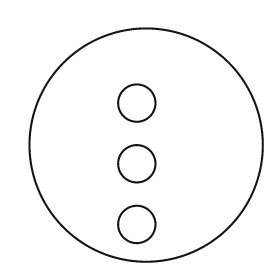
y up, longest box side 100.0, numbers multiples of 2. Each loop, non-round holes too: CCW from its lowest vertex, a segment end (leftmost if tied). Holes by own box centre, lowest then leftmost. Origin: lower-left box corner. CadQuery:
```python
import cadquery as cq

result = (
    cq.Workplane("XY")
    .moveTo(50.0, 50.0)
    .circle(50.0)
    .moveTo(46.0, 16.0)
    .circle(8.0)
    .moveTo(46.0, 42.0)
    .circle(8.0)
    .moveTo(46.0, 68.0)
    .circle(8.0)
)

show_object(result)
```